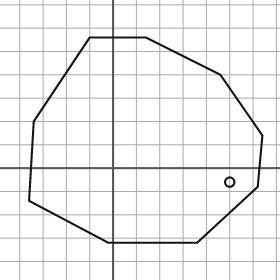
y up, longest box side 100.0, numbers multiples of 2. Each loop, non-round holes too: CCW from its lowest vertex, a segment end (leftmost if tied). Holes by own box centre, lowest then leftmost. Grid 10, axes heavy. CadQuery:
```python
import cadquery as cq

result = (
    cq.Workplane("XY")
    .moveTo(-2.0, -32.0)
    .lineTo(36.0, -32.0)
    .lineTo(62.0, -8.0)
    .lineTo(64.0, 14.0)
    .lineTo(46.0, 40.0)
    .lineTo(14.0, 56.0)
    .lineTo(-10.0, 56.0)
    .lineTo(-34.0, 20.0)
    .lineTo(-36.0, -14.0)
    .close()
    .moveTo(50.0, -6.0)
    .circle(2.0)
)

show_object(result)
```